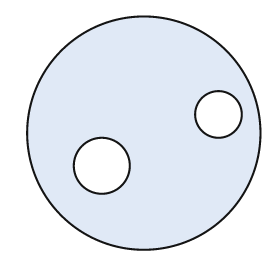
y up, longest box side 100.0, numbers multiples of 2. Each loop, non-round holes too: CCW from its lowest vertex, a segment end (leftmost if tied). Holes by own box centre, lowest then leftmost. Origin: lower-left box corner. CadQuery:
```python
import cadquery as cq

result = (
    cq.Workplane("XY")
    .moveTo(50.0, 50.0)
    .circle(50.0)
    .moveTo(32.0, 36.0)
    .circle(12.0)
    .moveTo(82.0, 58.0)
    .circle(10.0)
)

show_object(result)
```